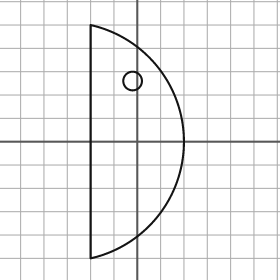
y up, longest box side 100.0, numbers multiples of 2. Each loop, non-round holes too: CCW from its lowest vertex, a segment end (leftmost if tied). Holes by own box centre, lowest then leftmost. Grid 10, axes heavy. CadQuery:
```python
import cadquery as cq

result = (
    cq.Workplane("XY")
    .moveTo(-20.0, -50.0)
    .threePointArc((20.0, 0.0), (-20.0, 50.0))
    .close()
    .moveTo(-2.0, 26.0)
    .circle(4.0)
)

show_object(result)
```